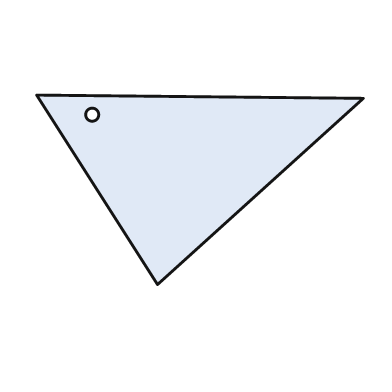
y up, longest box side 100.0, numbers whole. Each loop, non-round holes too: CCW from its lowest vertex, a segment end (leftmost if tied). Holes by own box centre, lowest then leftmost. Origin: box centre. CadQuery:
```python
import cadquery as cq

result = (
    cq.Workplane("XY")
    .moveTo(-13.0, -29.0)
    .lineTo(50.0, 28.0)
    .lineTo(-50.0, 29.0)
    .close()
    .moveTo(-33.0, 23.0)
    .circle(2.0)
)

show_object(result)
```